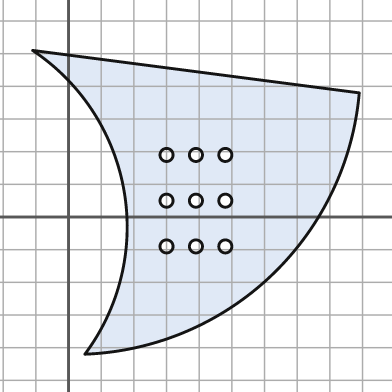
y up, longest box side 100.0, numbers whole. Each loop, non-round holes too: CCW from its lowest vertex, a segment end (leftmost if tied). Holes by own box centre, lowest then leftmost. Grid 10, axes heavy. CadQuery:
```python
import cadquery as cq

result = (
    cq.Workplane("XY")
    .moveTo(5.0, -42.0)
    .threePointArc((62.0, -18.0), (89.0, 38.0))
    .lineTo(-11.0, 51.0)
    .threePointArc((17.0, 8.0), (5.0, -42.0))
    .close()
    .moveTo(30.0, -9.0)
    .circle(2.0)
    .moveTo(39.0, -9.0)
    .circle(2.0)
    .moveTo(48.0, -9.0)
    .circle(2.0)
    .moveTo(30.0, 5.0)
    .circle(2.0)
    .moveTo(39.0, 5.0)
    .circle(2.0)
    .moveTo(48.0, 5.0)
    .circle(2.0)
    .moveTo(30.0, 19.0)
    .circle(2.0)
    .moveTo(39.0, 19.0)
    .circle(2.0)
    .moveTo(48.0, 19.0)
    .circle(2.0)
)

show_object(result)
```